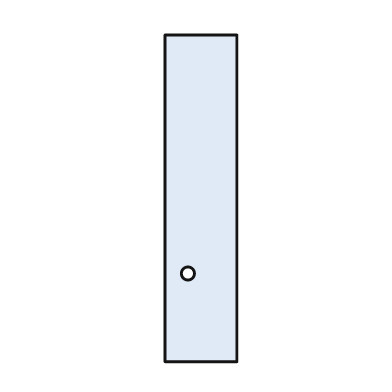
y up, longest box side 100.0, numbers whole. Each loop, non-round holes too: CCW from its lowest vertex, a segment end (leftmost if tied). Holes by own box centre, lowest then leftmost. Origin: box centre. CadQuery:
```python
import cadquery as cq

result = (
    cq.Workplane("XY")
    .moveTo(-11.0, -50.0)
    .lineTo(11.0, -50.0)
    .lineTo(11.0, 50.0)
    .lineTo(-11.0, 50.0)
    .close()
    .moveTo(-4.0, -23.0)
    .circle(2.0)
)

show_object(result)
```